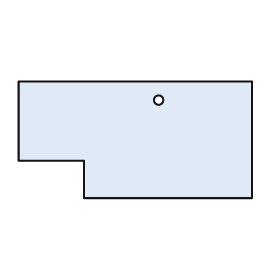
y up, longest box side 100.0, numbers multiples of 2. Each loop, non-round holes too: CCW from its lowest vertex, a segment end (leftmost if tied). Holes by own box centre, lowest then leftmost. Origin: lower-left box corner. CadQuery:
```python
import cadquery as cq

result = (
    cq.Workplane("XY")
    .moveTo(28.0, 0.0)
    .lineTo(100.0, 0.0)
    .lineTo(100.0, 50.0)
    .lineTo(0.0, 50.0)
    .lineTo(0.0, 16.0)
    .lineTo(28.0, 16.0)
    .close()
    .moveTo(60.0, 42.0)
    .circle(2.0)
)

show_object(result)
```